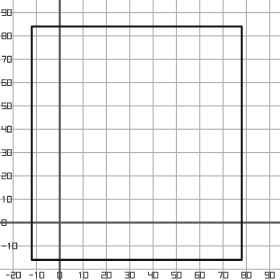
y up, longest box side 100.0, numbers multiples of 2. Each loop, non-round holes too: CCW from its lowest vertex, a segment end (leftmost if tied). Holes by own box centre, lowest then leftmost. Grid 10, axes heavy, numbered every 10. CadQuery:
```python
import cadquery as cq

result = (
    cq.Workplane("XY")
    .moveTo(-12.0, -16.0)
    .lineTo(78.0, -16.0)
    .lineTo(78.0, 84.0)
    .lineTo(-12.0, 84.0)
    .close()
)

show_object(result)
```